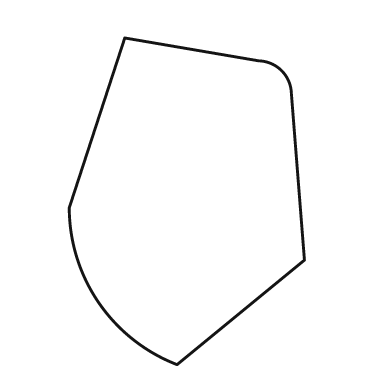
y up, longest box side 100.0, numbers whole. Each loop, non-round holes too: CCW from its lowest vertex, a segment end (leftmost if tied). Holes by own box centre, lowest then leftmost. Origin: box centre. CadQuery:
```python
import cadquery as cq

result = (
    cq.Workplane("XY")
    .moveTo(-3.0, -50.0)
    .lineTo(36.0, -18.0)
    .lineTo(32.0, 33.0)
    .threePointArc((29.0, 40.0), (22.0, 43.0))
    .lineTo(-19.0, 50.0)
    .lineTo(-36.0, -2.0)
    .threePointArc((-27.0, -31.0), (-3.0, -50.0))
    .close()
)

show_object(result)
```